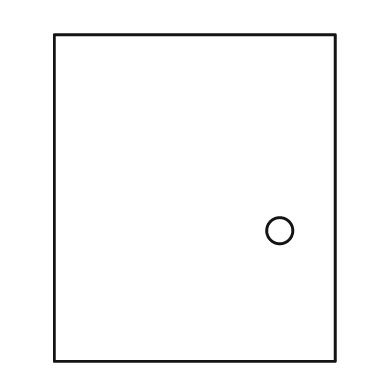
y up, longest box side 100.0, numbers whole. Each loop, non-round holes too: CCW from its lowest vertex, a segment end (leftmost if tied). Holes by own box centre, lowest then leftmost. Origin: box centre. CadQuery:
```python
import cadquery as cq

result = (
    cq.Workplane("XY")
    .moveTo(-43.0, -50.0)
    .lineTo(43.0, -50.0)
    .lineTo(43.0, 50.0)
    .lineTo(-43.0, 50.0)
    .close()
    .moveTo(26.0, -10.0)
    .circle(4.0)
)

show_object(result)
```